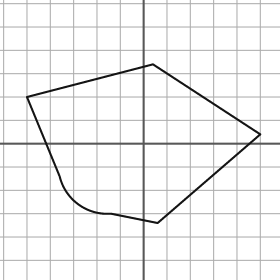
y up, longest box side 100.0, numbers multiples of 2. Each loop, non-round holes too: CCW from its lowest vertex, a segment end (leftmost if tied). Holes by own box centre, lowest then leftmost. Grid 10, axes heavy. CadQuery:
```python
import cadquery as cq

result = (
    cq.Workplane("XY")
    .moveTo(6.0, -34.0)
    .lineTo(50.0, 4.0)
    .lineTo(4.0, 34.0)
    .lineTo(-50.0, 20.0)
    .lineTo(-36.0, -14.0)
    .threePointArc((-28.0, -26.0), (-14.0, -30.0))
    .close()
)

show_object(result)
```